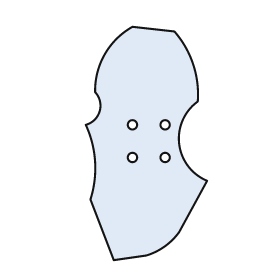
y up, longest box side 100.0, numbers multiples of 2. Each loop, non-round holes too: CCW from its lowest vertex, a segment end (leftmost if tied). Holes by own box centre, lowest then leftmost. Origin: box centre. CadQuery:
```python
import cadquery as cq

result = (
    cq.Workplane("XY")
    .moveTo(-14.0, -50.0)
    .lineTo(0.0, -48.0)
    .threePointArc((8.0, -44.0), (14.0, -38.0))
    .lineTo(26.0, -16.0)
    .threePointArc((14.0, 0.0), (22.0, 18.0))
    .threePointArc((20.0, 34.0), (12.0, 48.0))
    .lineTo(-6.0, 50.0)
    .threePointArc((-18.0, 38.0), (-22.0, 22.0))
    .threePointArc((-20.0, 14.0), (-26.0, 8.0))
    .threePointArc((-22.0, -8.0), (-24.0, -24.0))
    .close()
    .moveTo(-6.0, -6.0)
    .circle(2.0)
    .moveTo(8.0, -6.0)
    .circle(2.0)
    .moveTo(-6.0, 8.0)
    .circle(2.0)
    .moveTo(8.0, 8.0)
    .circle(2.0)
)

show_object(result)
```